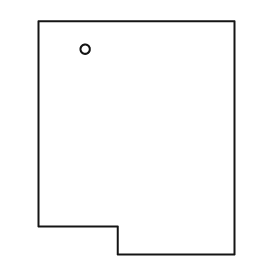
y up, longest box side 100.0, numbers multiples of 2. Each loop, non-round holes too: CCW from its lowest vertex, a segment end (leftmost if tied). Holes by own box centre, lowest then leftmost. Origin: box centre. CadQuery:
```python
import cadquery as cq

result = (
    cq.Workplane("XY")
    .moveTo(-8.0, -50.0)
    .lineTo(42.0, -50.0)
    .lineTo(42.0, 50.0)
    .lineTo(-42.0, 50.0)
    .lineTo(-42.0, -38.0)
    .lineTo(-8.0, -38.0)
    .close()
    .moveTo(-22.0, 38.0)
    .circle(2.0)
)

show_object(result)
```